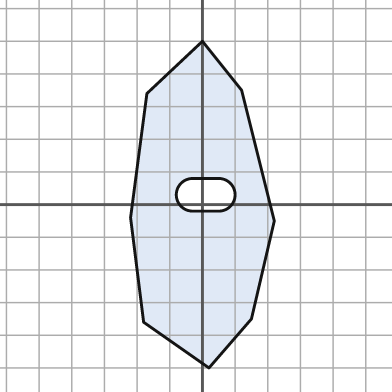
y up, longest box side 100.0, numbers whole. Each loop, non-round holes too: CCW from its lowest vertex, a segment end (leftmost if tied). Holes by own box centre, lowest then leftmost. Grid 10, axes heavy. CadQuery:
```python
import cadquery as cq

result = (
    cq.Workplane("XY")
    .moveTo(2.0, -50.0)
    .lineTo(15.0, -35.0)
    .lineTo(22.0, -5.0)
    .lineTo(12.0, 35.0)
    .lineTo(0.0, 50.0)
    .lineTo(-17.0, 34.0)
    .lineTo(-22.0, -4.0)
    .lineTo(-18.0, -36.0)
    .close()
    .moveTo(-3.0, -2.0)
    .lineTo(5.0, -2.0)
    .threePointArc((10.0, 3.0), (5.0, 8.0))
    .lineTo(-3.0, 8.0)
    .threePointArc((-8.0, 3.0), (-3.0, -2.0))
    .close()
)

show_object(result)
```